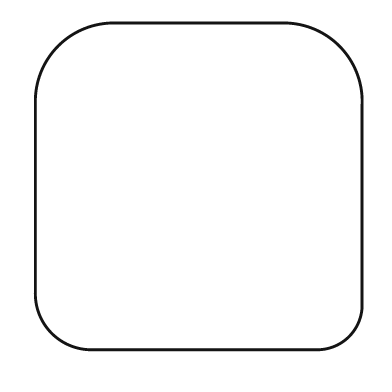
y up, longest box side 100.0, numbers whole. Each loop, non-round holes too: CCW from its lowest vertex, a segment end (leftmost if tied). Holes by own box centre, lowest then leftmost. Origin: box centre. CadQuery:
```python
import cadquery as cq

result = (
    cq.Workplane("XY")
    .moveTo(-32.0, -50.0)
    .lineTo(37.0, -50.0)
    .threePointArc((46.0, -46.0), (50.0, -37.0))
    .lineTo(50.0, 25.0)
    .threePointArc((43.0, 43.0), (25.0, 50.0))
    .lineTo(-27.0, 50.0)
    .threePointArc((-43.0, 43.0), (-50.0, 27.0))
    .lineTo(-50.0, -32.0)
    .threePointArc((-45.0, -45.0), (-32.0, -50.0))
    .close()
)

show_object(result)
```